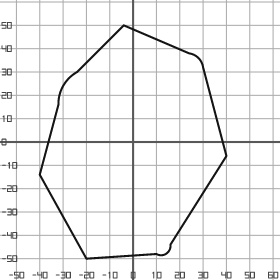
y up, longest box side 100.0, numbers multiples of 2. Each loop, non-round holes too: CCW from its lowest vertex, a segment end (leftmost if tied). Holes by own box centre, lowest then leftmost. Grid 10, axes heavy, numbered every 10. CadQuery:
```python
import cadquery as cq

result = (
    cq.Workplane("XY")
    .moveTo(-20.0, -50.0)
    .lineTo(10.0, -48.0)
    .threePointArc((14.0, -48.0), (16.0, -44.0))
    .lineTo(40.0, -6.0)
    .lineTo(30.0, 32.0)
    .threePointArc((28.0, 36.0), (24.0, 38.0))
    .lineTo(-4.0, 50.0)
    .lineTo(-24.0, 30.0)
    .threePointArc((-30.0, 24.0), (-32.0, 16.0))
    .lineTo(-40.0, -14.0)
    .close()
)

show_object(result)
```